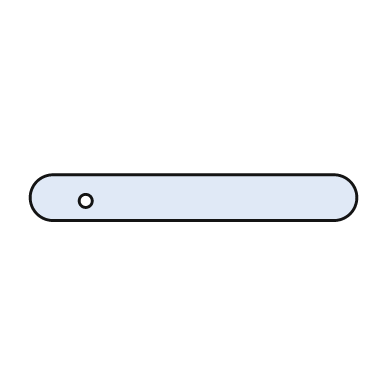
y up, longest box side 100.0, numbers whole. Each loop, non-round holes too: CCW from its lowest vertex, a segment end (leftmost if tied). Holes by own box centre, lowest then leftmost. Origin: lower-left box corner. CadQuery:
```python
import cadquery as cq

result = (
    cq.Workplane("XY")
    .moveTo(7.0, 0.0)
    .lineTo(93.0, 0.0)
    .threePointArc((100.0, 7.0), (93.0, 14.0))
    .lineTo(7.0, 14.0)
    .threePointArc((0.0, 7.0), (7.0, 0.0))
    .close()
    .moveTo(17.0, 6.0)
    .circle(2.0)
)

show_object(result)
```